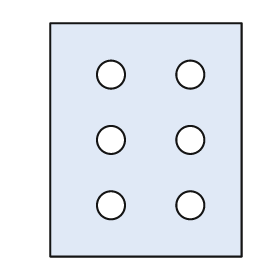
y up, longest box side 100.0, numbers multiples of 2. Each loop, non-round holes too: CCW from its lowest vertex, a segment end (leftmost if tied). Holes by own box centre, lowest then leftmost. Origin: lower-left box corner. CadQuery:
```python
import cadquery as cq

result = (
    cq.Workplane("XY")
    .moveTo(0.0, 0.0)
    .lineTo(82.0, 0.0)
    .lineTo(82.0, 100.0)
    .lineTo(0.0, 100.0)
    .close()
    .moveTo(26.0, 22.0)
    .circle(6.0)
    .moveTo(60.0, 22.0)
    .circle(6.0)
    .moveTo(26.0, 50.0)
    .circle(6.0)
    .moveTo(60.0, 50.0)
    .circle(6.0)
    .moveTo(26.0, 78.0)
    .circle(6.0)
    .moveTo(60.0, 78.0)
    .circle(6.0)
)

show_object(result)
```